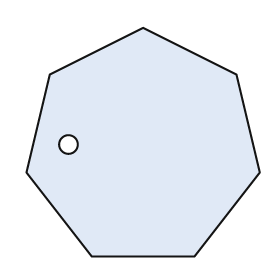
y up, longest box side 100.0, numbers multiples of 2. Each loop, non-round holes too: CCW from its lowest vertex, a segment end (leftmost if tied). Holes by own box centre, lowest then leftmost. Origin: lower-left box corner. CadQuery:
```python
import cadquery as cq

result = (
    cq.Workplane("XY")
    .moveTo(28.0, 0.0)
    .lineTo(72.0, 0.0)
    .lineTo(100.0, 36.0)
    .lineTo(90.0, 78.0)
    .lineTo(50.0, 98.0)
    .lineTo(10.0, 78.0)
    .lineTo(0.0, 36.0)
    .close()
    .moveTo(18.0, 48.0)
    .circle(4.0)
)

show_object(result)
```